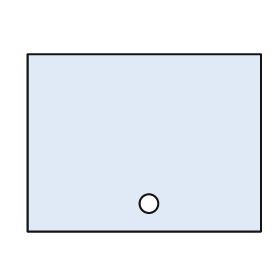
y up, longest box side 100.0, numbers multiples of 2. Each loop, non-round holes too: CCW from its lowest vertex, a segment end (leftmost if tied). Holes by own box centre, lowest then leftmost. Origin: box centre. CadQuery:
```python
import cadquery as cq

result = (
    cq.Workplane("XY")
    .moveTo(-50.0, -38.0)
    .lineTo(50.0, -38.0)
    .lineTo(50.0, 38.0)
    .lineTo(-50.0, 38.0)
    .close()
    .moveTo(2.0, -26.0)
    .circle(4.0)
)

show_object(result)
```